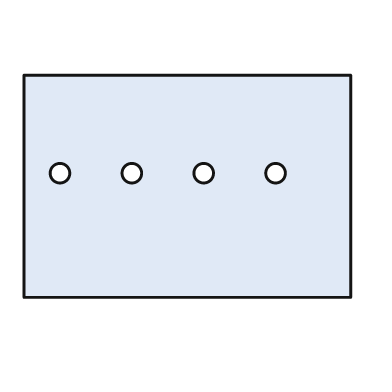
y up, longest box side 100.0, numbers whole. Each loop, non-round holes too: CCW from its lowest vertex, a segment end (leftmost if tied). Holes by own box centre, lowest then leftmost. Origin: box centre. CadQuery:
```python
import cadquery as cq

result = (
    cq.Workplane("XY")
    .moveTo(-50.0, -34.0)
    .lineTo(50.0, -34.0)
    .lineTo(50.0, 34.0)
    .lineTo(-50.0, 34.0)
    .close()
    .moveTo(-39.0, 4.0)
    .circle(3.0)
    .moveTo(-17.0, 4.0)
    .circle(3.0)
    .moveTo(5.0, 4.0)
    .circle(3.0)
    .moveTo(27.0, 4.0)
    .circle(3.0)
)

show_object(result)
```